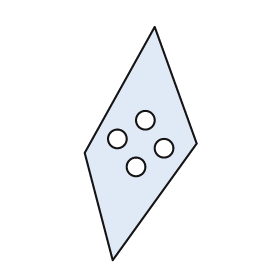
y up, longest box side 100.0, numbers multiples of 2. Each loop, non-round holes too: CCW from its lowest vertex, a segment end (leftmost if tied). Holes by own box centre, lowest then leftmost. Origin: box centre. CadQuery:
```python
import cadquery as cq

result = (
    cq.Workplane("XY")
    .moveTo(-12.0, -50.0)
    .lineTo(24.0, 0.0)
    .lineTo(6.0, 50.0)
    .lineTo(-24.0, -4.0)
    .close()
    .moveTo(-2.0, -10.0)
    .circle(4.0)
    .moveTo(10.0, -2.0)
    .circle(4.0)
    .moveTo(-10.0, 2.0)
    .circle(4.0)
    .moveTo(2.0, 10.0)
    .circle(4.0)
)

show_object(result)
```